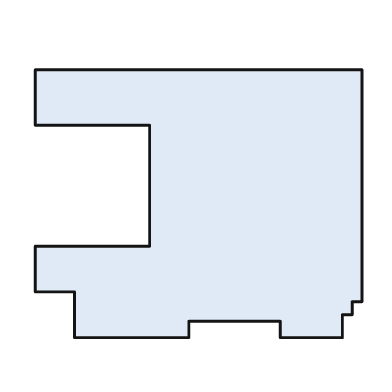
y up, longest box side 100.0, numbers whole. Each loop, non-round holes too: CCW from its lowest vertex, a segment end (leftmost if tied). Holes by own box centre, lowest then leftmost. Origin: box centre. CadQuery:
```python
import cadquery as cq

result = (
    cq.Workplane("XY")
    .moveTo(-38.0, -41.0)
    .lineTo(-3.0, -41.0)
    .lineTo(-3.0, -36.0)
    .lineTo(25.0, -36.0)
    .lineTo(25.0, -41.0)
    .lineTo(44.0, -41.0)
    .lineTo(44.0, -34.0)
    .lineTo(47.0, -34.0)
    .lineTo(47.0, -30.0)
    .lineTo(50.0, -30.0)
    .lineTo(50.0, 41.0)
    .lineTo(-50.0, 41.0)
    .lineTo(-50.0, 24.0)
    .lineTo(-15.0, 24.0)
    .lineTo(-15.0, -13.0)
    .lineTo(-50.0, -13.0)
    .lineTo(-50.0, -27.0)
    .lineTo(-38.0, -27.0)
    .close()
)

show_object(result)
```